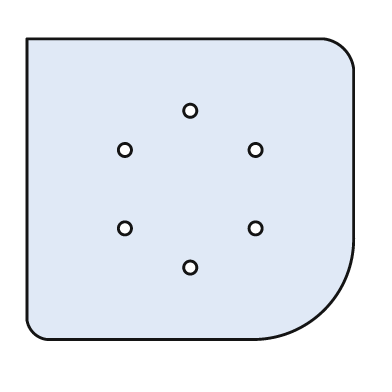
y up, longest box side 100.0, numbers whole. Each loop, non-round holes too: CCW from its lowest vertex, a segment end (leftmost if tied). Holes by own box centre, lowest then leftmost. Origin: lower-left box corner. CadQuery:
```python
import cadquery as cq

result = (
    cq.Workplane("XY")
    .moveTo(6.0, 0.0)
    .lineTo(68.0, 0.0)
    .threePointArc((91.0, 9.0), (100.0, 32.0))
    .lineTo(100.0, 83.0)
    .threePointArc((97.0, 89.0), (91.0, 92.0))
    .lineTo(0.0, 92.0)
    .lineTo(0.0, 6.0)
    .threePointArc((2.0, 2.0), (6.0, 0.0))
    .close()
    .moveTo(50.0, 22.0)
    .circle(2.0)
    .moveTo(30.0, 34.0)
    .circle(2.0)
    .moveTo(70.0, 34.0)
    .circle(2.0)
    .moveTo(30.0, 58.0)
    .circle(2.0)
    .moveTo(70.0, 58.0)
    .circle(2.0)
    .moveTo(50.0, 70.0)
    .circle(2.0)
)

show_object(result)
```